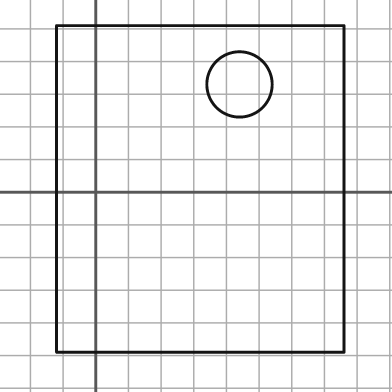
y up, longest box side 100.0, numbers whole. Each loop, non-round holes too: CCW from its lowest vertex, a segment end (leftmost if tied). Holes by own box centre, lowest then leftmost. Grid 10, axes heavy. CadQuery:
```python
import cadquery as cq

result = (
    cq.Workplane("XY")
    .moveTo(-12.0, -49.0)
    .lineTo(76.0, -49.0)
    .lineTo(76.0, 51.0)
    .lineTo(-12.0, 51.0)
    .close()
    .moveTo(44.0, 33.0)
    .circle(10.0)
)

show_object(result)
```